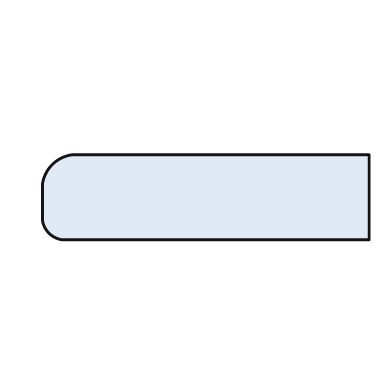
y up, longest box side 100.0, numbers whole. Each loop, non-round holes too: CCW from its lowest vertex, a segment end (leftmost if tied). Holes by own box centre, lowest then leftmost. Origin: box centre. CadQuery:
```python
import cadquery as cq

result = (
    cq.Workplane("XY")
    .moveTo(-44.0, -13.0)
    .lineTo(50.0, -13.0)
    .lineTo(50.0, 13.0)
    .lineTo(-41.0, 13.0)
    .threePointArc((-47.0, 10.0), (-50.0, 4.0))
    .lineTo(-50.0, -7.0)
    .threePointArc((-48.0, -11.0), (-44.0, -13.0))
    .close()
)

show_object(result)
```